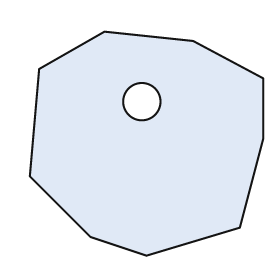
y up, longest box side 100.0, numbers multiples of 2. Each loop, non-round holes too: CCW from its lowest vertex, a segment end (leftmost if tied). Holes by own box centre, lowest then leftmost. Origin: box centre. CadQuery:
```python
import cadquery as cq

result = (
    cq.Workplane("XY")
    .moveTo(0.0, -48.0)
    .lineTo(40.0, -36.0)
    .lineTo(50.0, 2.0)
    .lineTo(50.0, 28.0)
    .lineTo(20.0, 44.0)
    .lineTo(-18.0, 48.0)
    .lineTo(-46.0, 32.0)
    .lineTo(-50.0, -14.0)
    .lineTo(-24.0, -40.0)
    .close()
    .moveTo(-2.0, 18.0)
    .circle(8.0)
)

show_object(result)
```